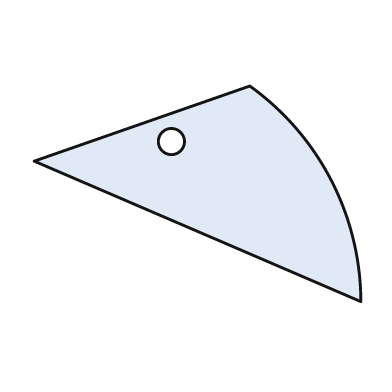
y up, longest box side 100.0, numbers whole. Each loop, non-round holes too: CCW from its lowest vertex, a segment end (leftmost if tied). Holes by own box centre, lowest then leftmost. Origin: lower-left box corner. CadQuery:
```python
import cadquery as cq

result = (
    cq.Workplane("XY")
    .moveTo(100.0, 0.0)
    .threePointArc((91.0, 37.0), (66.0, 66.0))
    .lineTo(0.0, 43.0)
    .close()
    .moveTo(42.0, 49.0)
    .circle(4.0)
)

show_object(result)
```